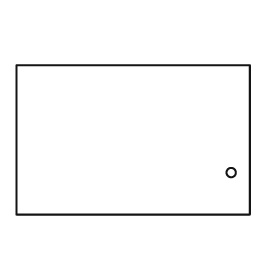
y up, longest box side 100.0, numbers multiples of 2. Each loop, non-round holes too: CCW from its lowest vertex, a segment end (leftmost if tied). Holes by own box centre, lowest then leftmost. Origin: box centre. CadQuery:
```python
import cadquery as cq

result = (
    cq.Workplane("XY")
    .moveTo(-50.0, -32.0)
    .lineTo(50.0, -32.0)
    .lineTo(50.0, 32.0)
    .lineTo(-50.0, 32.0)
    .close()
    .moveTo(42.0, -14.0)
    .circle(2.0)
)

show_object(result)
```